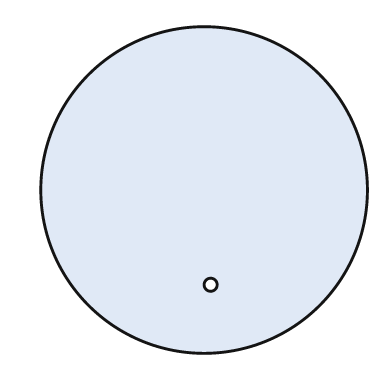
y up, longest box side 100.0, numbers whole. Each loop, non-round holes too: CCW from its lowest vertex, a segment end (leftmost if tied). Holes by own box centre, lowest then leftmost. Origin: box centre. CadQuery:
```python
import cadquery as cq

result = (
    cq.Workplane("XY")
    .moveTo(0.0, 0.0)
    .circle(50.0)
    .moveTo(2.0, -29.0)
    .circle(2.0)
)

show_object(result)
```